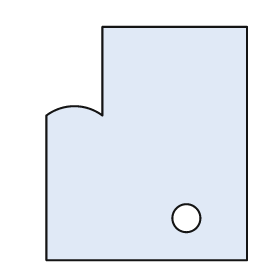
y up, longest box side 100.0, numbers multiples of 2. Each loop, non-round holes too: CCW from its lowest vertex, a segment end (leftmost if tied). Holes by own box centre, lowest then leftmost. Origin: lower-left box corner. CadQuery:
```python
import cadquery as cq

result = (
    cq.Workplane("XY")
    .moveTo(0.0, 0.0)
    .lineTo(86.0, 0.0)
    .lineTo(86.0, 100.0)
    .lineTo(24.0, 100.0)
    .lineTo(24.0, 62.0)
    .threePointArc((12.0, 66.0), (0.0, 62.0))
    .close()
    .moveTo(60.0, 18.0)
    .circle(6.0)
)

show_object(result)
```